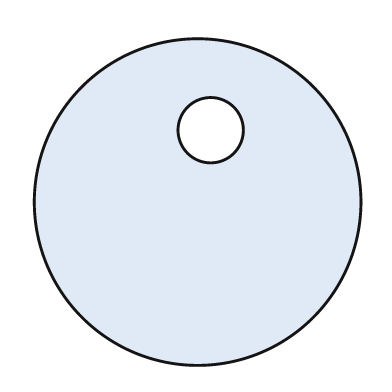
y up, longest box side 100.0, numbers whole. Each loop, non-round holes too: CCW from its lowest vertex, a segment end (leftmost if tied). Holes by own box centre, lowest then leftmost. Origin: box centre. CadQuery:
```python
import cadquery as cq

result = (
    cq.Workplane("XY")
    .moveTo(0.0, 0.0)
    .circle(50.0)
    .moveTo(4.0, 22.0)
    .circle(10.0)
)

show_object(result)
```